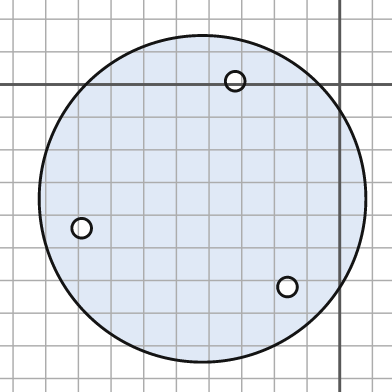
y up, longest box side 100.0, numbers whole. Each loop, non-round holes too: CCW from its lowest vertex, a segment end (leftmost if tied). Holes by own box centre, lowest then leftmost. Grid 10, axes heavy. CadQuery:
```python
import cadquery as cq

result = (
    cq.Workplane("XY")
    .moveTo(-42.0, -35.0)
    .circle(50.0)
    .moveTo(-16.0, -62.0)
    .circle(3.0)
    .moveTo(-79.0, -44.0)
    .circle(3.0)
    .moveTo(-32.0, 1.0)
    .circle(3.0)
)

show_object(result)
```